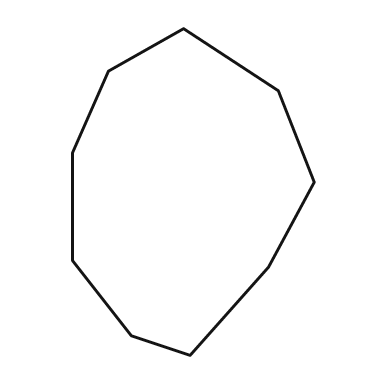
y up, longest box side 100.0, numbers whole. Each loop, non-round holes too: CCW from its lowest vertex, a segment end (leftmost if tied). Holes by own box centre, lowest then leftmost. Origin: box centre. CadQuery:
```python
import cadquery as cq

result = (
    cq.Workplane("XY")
    .moveTo(-1.0, -50.0)
    .lineTo(23.0, -23.0)
    .lineTo(37.0, 3.0)
    .lineTo(26.0, 31.0)
    .lineTo(-3.0, 50.0)
    .lineTo(-26.0, 37.0)
    .lineTo(-37.0, 12.0)
    .lineTo(-37.0, -21.0)
    .lineTo(-19.0, -44.0)
    .close()
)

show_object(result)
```